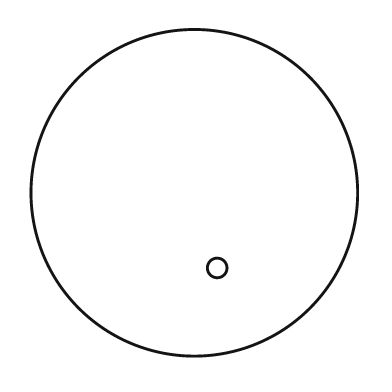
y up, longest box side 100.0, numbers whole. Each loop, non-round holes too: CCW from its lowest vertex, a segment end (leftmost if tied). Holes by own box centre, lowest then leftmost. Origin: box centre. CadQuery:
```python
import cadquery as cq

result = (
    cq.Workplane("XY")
    .moveTo(0.0, 0.0)
    .circle(50.0)
    .moveTo(7.0, -23.0)
    .circle(3.0)
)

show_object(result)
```